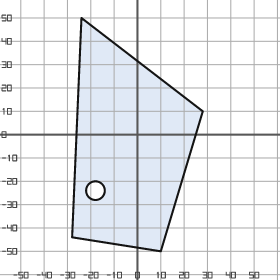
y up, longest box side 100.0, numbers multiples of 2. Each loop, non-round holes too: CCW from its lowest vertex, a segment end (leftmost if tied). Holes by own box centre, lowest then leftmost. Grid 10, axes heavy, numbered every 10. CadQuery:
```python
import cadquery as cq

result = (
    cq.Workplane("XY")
    .moveTo(10.0, -50.0)
    .lineTo(28.0, 10.0)
    .lineTo(-24.0, 50.0)
    .lineTo(-28.0, -44.0)
    .close()
    .moveTo(-18.0, -24.0)
    .circle(4.0)
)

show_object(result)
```